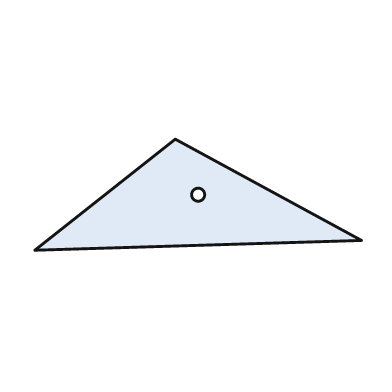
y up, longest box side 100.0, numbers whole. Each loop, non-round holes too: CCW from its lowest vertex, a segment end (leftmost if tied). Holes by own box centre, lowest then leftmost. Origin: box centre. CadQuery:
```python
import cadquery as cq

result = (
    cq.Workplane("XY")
    .moveTo(-50.0, -17.0)
    .lineTo(50.0, -14.0)
    .lineTo(-7.0, 17.0)
    .close()
    .moveTo(0.0, 0.0)
    .circle(2.0)
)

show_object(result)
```